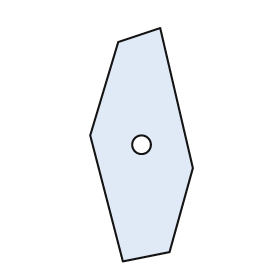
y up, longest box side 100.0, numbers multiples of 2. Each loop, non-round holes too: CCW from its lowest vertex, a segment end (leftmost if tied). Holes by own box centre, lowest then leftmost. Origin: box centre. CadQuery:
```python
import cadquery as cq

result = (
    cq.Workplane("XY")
    .moveTo(-8.0, -50.0)
    .lineTo(12.0, -46.0)
    .lineTo(22.0, -10.0)
    .lineTo(8.0, 50.0)
    .lineTo(-10.0, 44.0)
    .lineTo(-22.0, 4.0)
    .close()
    .moveTo(0.0, 0.0)
    .circle(4.0)
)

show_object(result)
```